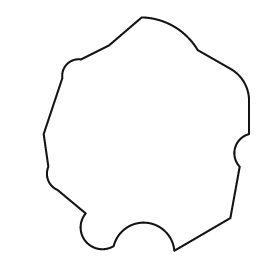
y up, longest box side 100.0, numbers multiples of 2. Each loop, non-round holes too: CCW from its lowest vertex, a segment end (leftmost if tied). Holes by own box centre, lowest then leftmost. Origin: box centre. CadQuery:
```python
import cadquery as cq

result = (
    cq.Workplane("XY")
    .moveTo(12.0, -50.0)
    .lineTo(36.0, -36.0)
    .lineTo(40.0, -14.0)
    .threePointArc((38.0, -6.0), (44.0, 0.0))
    .lineTo(44.0, 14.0)
    .threePointArc((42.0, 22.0), (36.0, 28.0))
    .lineTo(22.0, 36.0)
    .threePointArc((12.0, 46.0), (-2.0, 50.0))
    .lineTo(-16.0, 38.0)
    .lineTo(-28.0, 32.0)
    .threePointArc((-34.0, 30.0), (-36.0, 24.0))
    .lineTo(-44.0, 0.0)
    .lineTo(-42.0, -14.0)
    .threePointArc((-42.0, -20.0), (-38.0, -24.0))
    .lineTo(-26.0, -34.0)
    .threePointArc((-26.0, -46.0), (-14.0, -48.0))
    .threePointArc((0.0, -38.0), (12.0, -50.0))
    .close()
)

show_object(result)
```